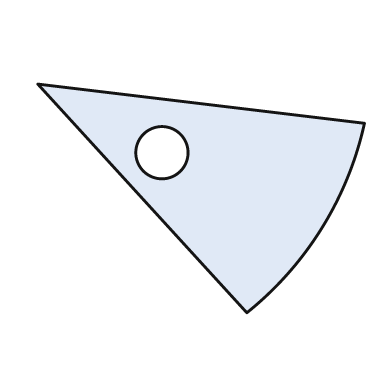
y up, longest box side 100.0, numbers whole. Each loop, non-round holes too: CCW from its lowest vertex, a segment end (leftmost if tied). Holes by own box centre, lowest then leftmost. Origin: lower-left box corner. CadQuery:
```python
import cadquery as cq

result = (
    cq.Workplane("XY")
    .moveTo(64.0, 0.0)
    .threePointArc((87.0, 26.0), (100.0, 58.0))
    .lineTo(0.0, 70.0)
    .close()
    .moveTo(38.0, 49.0)
    .circle(8.0)
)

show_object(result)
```